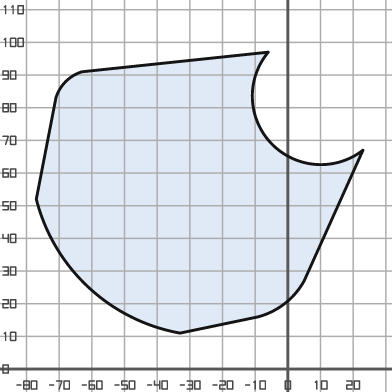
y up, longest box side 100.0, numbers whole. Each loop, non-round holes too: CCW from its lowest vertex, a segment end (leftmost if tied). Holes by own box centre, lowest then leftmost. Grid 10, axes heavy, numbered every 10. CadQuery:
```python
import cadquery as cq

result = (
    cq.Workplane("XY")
    .moveTo(-33.0, 11.0)
    .lineTo(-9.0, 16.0)
    .threePointArc((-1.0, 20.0), (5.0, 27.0))
    .lineTo(23.0, 67.0)
    .threePointArc((-5.0, 69.0), (-6.0, 97.0))
    .lineTo(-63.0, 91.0)
    .threePointArc((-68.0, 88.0), (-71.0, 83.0))
    .lineTo(-77.0, 52.0)
    .threePointArc((-61.0, 25.0), (-33.0, 11.0))
    .close()
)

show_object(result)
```